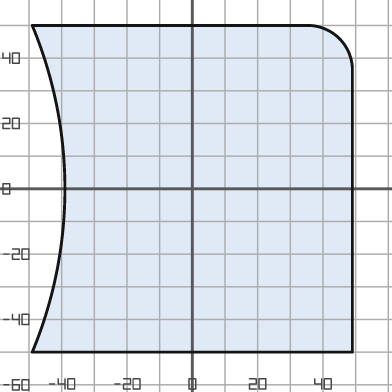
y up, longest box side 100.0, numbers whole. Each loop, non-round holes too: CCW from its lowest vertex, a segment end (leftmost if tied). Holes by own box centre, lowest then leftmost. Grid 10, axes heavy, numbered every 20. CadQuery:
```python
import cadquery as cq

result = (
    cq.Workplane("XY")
    .moveTo(-49.0, -50.0)
    .lineTo(49.0, -50.0)
    .lineTo(49.0, 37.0)
    .threePointArc((45.0, 46.0), (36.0, 50.0))
    .lineTo(-49.0, 50.0)
    .threePointArc((-39.0, 0.0), (-49.0, -50.0))
    .close()
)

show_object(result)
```